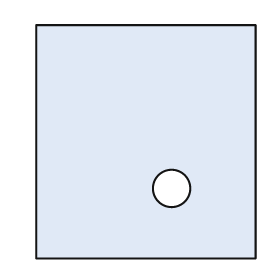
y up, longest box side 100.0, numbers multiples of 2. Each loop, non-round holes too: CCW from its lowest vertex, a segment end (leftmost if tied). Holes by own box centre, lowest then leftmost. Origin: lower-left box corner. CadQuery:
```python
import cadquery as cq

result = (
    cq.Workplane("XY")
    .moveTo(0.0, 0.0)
    .lineTo(94.0, 0.0)
    .lineTo(94.0, 100.0)
    .lineTo(0.0, 100.0)
    .close()
    .moveTo(58.0, 30.0)
    .circle(8.0)
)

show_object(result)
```